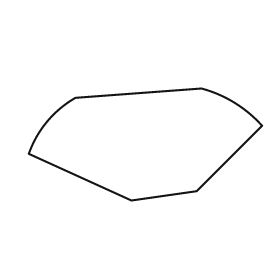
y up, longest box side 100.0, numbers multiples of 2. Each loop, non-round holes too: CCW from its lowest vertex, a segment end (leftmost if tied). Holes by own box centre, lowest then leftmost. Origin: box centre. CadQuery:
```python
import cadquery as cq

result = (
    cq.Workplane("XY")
    .moveTo(-6.0, -24.0)
    .lineTo(22.0, -20.0)
    .lineTo(50.0, 8.0)
    .threePointArc((38.0, 18.0), (24.0, 24.0))
    .lineTo(-30.0, 20.0)
    .threePointArc((-42.0, 10.0), (-50.0, -4.0))
    .close()
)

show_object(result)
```